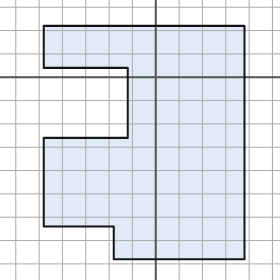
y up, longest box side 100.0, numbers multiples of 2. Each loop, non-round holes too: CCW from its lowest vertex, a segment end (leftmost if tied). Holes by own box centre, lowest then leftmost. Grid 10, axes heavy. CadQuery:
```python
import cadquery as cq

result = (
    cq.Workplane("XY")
    .moveTo(-18.0, -78.0)
    .lineTo(38.0, -78.0)
    .lineTo(38.0, 22.0)
    .lineTo(-48.0, 22.0)
    .lineTo(-48.0, 4.0)
    .lineTo(-12.0, 4.0)
    .lineTo(-12.0, -26.0)
    .lineTo(-48.0, -26.0)
    .lineTo(-48.0, -64.0)
    .lineTo(-18.0, -64.0)
    .close()
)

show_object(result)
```